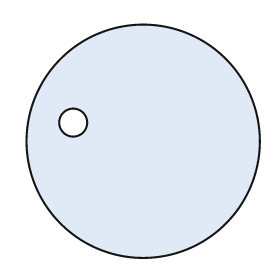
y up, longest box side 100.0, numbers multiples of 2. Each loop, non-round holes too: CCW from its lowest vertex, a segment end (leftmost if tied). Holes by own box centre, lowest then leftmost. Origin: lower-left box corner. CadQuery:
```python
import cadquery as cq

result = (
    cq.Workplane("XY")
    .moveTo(50.0, 50.0)
    .circle(50.0)
    .moveTo(20.0, 58.0)
    .circle(6.0)
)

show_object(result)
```